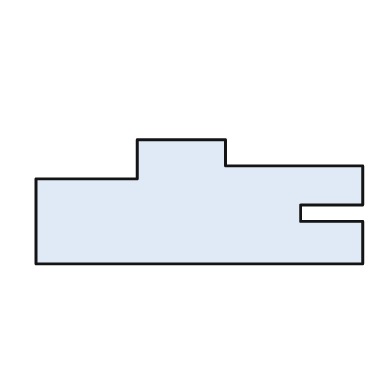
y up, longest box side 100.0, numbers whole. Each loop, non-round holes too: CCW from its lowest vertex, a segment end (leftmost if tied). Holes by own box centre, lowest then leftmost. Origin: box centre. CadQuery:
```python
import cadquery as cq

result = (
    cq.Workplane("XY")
    .moveTo(-50.0, -19.0)
    .lineTo(50.0, -19.0)
    .lineTo(50.0, -6.0)
    .lineTo(31.0, -6.0)
    .lineTo(31.0, -1.0)
    .lineTo(50.0, -1.0)
    .lineTo(50.0, 11.0)
    .lineTo(8.0, 11.0)
    .lineTo(8.0, 19.0)
    .lineTo(-19.0, 19.0)
    .lineTo(-19.0, 7.0)
    .lineTo(-50.0, 7.0)
    .close()
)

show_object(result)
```